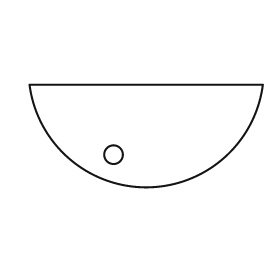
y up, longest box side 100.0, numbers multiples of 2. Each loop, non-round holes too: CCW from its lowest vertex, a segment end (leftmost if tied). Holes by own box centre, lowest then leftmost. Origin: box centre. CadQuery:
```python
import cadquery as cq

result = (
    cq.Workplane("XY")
    .moveTo(-50.0, 22.0)
    .threePointArc((0.0, -22.0), (50.0, 22.0))
    .close()
    .moveTo(-14.0, -8.0)
    .circle(4.0)
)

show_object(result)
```